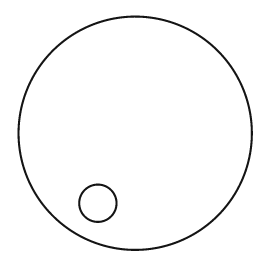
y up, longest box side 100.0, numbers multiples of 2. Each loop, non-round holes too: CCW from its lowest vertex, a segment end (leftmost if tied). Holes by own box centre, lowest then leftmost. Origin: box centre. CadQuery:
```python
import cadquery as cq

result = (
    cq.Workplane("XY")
    .moveTo(0.0, 0.0)
    .circle(50.0)
    .moveTo(-16.0, -30.0)
    .circle(8.0)
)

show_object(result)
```